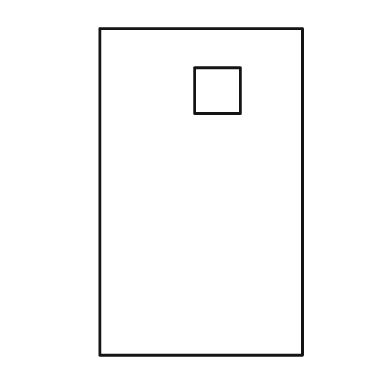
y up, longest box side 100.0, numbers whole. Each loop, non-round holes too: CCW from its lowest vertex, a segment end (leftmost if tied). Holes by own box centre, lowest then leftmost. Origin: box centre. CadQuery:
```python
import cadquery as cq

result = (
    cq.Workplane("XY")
    .moveTo(-31.0, -50.0)
    .lineTo(31.0, -50.0)
    .lineTo(31.0, 50.0)
    .lineTo(-31.0, 50.0)
    .close()
    .moveTo(-2.0, 24.0)
    .lineTo(12.0, 24.0)
    .lineTo(12.0, 38.0)
    .lineTo(-2.0, 38.0)
    .close()
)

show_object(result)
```